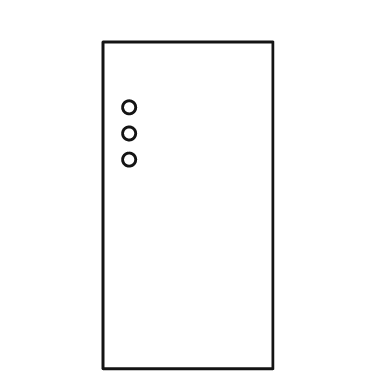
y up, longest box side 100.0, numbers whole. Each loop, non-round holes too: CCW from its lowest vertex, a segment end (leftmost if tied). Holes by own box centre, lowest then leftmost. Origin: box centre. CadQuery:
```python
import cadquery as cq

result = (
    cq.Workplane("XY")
    .moveTo(-26.0, -50.0)
    .lineTo(26.0, -50.0)
    .lineTo(26.0, 50.0)
    .lineTo(-26.0, 50.0)
    .close()
    .moveTo(-18.0, 14.0)
    .circle(2.0)
    .moveTo(-18.0, 22.0)
    .circle(2.0)
    .moveTo(-18.0, 30.0)
    .circle(2.0)
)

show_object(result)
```